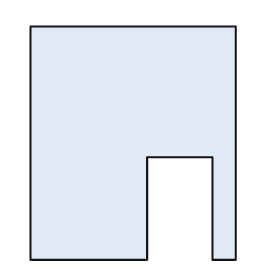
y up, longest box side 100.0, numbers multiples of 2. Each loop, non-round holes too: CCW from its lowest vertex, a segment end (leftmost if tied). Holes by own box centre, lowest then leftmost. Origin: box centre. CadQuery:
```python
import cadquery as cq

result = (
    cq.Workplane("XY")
    .moveTo(-44.0, -50.0)
    .lineTo(6.0, -50.0)
    .lineTo(6.0, -6.0)
    .lineTo(34.0, -6.0)
    .lineTo(34.0, -50.0)
    .lineTo(44.0, -50.0)
    .lineTo(44.0, 50.0)
    .lineTo(-44.0, 50.0)
    .close()
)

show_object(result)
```